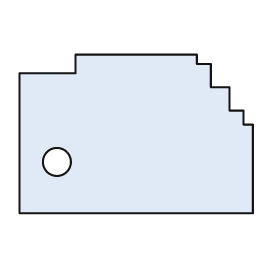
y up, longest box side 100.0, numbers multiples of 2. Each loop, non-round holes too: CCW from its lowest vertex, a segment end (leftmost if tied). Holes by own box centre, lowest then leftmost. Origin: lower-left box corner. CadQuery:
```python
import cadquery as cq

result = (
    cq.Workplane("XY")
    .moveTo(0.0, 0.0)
    .lineTo(100.0, 0.0)
    .lineTo(100.0, 38.0)
    .lineTo(96.0, 38.0)
    .lineTo(96.0, 44.0)
    .lineTo(90.0, 44.0)
    .lineTo(90.0, 54.0)
    .lineTo(82.0, 54.0)
    .lineTo(82.0, 64.0)
    .lineTo(76.0, 64.0)
    .lineTo(76.0, 68.0)
    .lineTo(24.0, 68.0)
    .lineTo(24.0, 60.0)
    .lineTo(0.0, 60.0)
    .close()
    .moveTo(16.0, 22.0)
    .circle(6.0)
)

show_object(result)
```